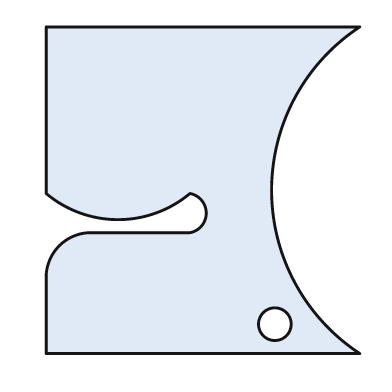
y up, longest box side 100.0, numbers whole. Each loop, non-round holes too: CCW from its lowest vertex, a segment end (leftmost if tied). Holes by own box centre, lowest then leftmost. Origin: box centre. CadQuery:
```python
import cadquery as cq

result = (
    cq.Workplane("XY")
    .moveTo(-48.0, -50.0)
    .lineTo(48.0, -50.0)
    .threePointArc((21.0, 0.0), (48.0, 50.0))
    .lineTo(-48.0, 50.0)
    .lineTo(-48.0, -1.0)
    .threePointArc((-26.0, -9.0), (-4.0, -1.0))
    .threePointArc((1.0, -7.0), (-4.0, -13.0))
    .lineTo(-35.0, -13.0)
    .threePointArc((-44.0, -17.0), (-48.0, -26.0))
    .close()
    .moveTo(22.0, -41.0)
    .circle(5.0)
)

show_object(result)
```